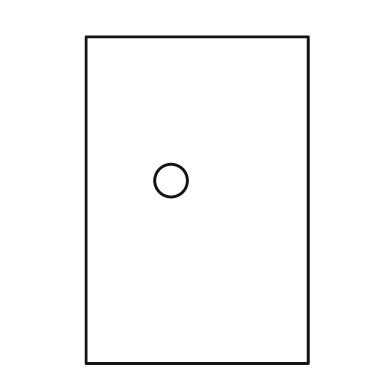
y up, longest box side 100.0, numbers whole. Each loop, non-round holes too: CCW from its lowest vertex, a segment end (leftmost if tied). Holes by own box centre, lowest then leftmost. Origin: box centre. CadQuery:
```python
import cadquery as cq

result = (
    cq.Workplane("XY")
    .moveTo(-34.0, -50.0)
    .lineTo(34.0, -50.0)
    .lineTo(34.0, 50.0)
    .lineTo(-34.0, 50.0)
    .close()
    .moveTo(-8.0, 6.0)
    .circle(5.0)
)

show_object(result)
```